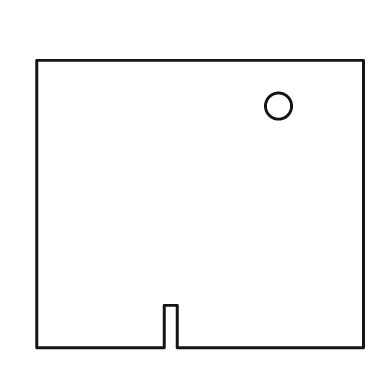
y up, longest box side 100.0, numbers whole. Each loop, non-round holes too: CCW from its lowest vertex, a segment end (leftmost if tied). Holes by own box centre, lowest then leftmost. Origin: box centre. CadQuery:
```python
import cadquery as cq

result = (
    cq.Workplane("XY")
    .moveTo(-50.0, -44.0)
    .lineTo(-11.0, -44.0)
    .lineTo(-11.0, -31.0)
    .lineTo(-7.0, -31.0)
    .lineTo(-7.0, -44.0)
    .lineTo(50.0, -44.0)
    .lineTo(50.0, 44.0)
    .lineTo(-50.0, 44.0)
    .close()
    .moveTo(24.0, 30.0)
    .circle(4.0)
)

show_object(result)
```